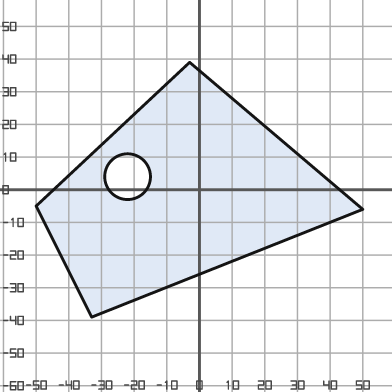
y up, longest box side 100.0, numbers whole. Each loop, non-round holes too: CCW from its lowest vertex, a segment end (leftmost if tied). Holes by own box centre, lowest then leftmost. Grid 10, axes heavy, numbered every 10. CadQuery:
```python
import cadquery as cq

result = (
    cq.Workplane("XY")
    .moveTo(-33.0, -39.0)
    .lineTo(50.0, -6.0)
    .lineTo(-3.0, 39.0)
    .lineTo(-50.0, -5.0)
    .close()
    .moveTo(-22.0, 4.0)
    .circle(7.0)
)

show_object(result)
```